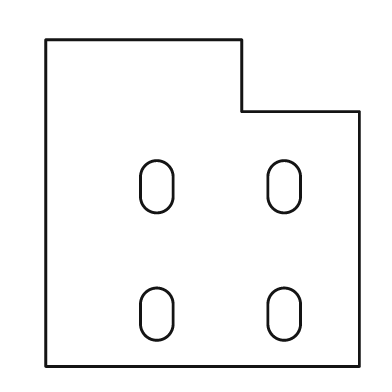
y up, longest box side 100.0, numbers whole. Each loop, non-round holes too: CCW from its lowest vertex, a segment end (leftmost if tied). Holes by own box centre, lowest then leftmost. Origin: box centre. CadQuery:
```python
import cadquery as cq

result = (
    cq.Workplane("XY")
    .moveTo(-48.0, -50.0)
    .lineTo(48.0, -50.0)
    .lineTo(48.0, 28.0)
    .lineTo(12.0, 28.0)
    .lineTo(12.0, 50.0)
    .lineTo(-48.0, 50.0)
    .close()
    .moveTo(-19.0, -37.0)
    .threePointArc((-14.0, -42.0), (-9.0, -37.0))
    .lineTo(-9.0, -31.0)
    .threePointArc((-14.0, -26.0), (-19.0, -31.0))
    .close()
    .moveTo(20.0, -37.0)
    .threePointArc((25.0, -42.0), (30.0, -37.0))
    .lineTo(30.0, -31.0)
    .threePointArc((25.0, -26.0), (20.0, -31.0))
    .close()
    .moveTo(-19.0, 2.0)
    .threePointArc((-14.0, -3.0), (-9.0, 2.0))
    .lineTo(-9.0, 8.0)
    .threePointArc((-14.0, 13.0), (-19.0, 8.0))
    .close()
    .moveTo(20.0, 2.0)
    .threePointArc((25.0, -3.0), (30.0, 2.0))
    .lineTo(30.0, 8.0)
    .threePointArc((25.0, 13.0), (20.0, 8.0))
    .close()
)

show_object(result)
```